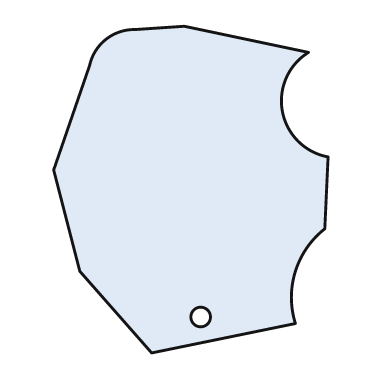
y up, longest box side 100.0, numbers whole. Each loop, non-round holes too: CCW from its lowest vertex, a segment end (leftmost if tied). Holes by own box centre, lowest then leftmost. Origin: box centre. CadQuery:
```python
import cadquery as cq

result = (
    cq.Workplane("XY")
    .moveTo(-12.0, -50.0)
    .lineTo(32.0, -41.0)
    .threePointArc((32.0, -25.0), (41.0, -12.0))
    .lineTo(42.0, 10.0)
    .threePointArc((28.0, 24.0), (36.0, 42.0))
    .lineTo(-2.0, 50.0)
    .lineTo(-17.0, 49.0)
    .threePointArc((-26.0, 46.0), (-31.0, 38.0))
    .lineTo(-42.0, 6.0)
    .lineTo(-34.0, -25.0)
    .close()
    .moveTo(3.0, -39.0)
    .circle(3.0)
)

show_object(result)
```